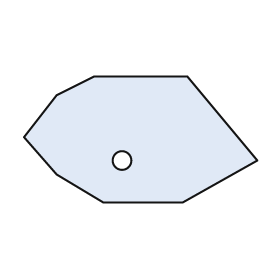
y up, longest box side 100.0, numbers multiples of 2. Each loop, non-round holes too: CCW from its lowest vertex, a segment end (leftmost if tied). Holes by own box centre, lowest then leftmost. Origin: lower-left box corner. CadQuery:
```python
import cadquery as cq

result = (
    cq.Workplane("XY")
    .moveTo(34.0, 0.0)
    .lineTo(68.0, 0.0)
    .lineTo(100.0, 18.0)
    .lineTo(70.0, 54.0)
    .lineTo(30.0, 54.0)
    .lineTo(14.0, 46.0)
    .lineTo(0.0, 28.0)
    .lineTo(14.0, 12.0)
    .close()
    .moveTo(42.0, 18.0)
    .circle(4.0)
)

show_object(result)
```